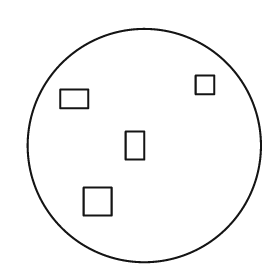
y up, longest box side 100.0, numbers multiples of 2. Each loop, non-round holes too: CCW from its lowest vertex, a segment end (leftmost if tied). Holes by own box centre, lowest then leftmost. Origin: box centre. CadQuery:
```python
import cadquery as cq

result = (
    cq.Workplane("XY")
    .moveTo(0.0, 0.0)
    .circle(50.0)
    .moveTo(-26.0, -30.0)
    .lineTo(-14.0, -30.0)
    .lineTo(-14.0, -18.0)
    .lineTo(-26.0, -18.0)
    .close()
    .moveTo(-8.0, -6.0)
    .lineTo(0.0, -6.0)
    .lineTo(0.0, 6.0)
    .lineTo(-8.0, 6.0)
    .close()
    .moveTo(-36.0, 16.0)
    .lineTo(-24.0, 16.0)
    .lineTo(-24.0, 24.0)
    .lineTo(-36.0, 24.0)
    .close()
    .moveTo(22.0, 22.0)
    .lineTo(30.0, 22.0)
    .lineTo(30.0, 30.0)
    .lineTo(22.0, 30.0)
    .close()
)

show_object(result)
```